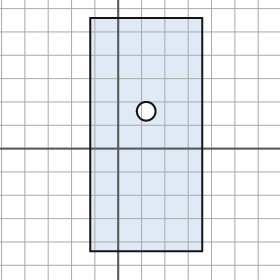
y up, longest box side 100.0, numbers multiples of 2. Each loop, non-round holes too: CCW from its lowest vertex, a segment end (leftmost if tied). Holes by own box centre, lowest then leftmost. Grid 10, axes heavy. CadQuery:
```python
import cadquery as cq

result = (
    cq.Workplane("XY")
    .moveTo(-12.0, -44.0)
    .lineTo(36.0, -44.0)
    .lineTo(36.0, 56.0)
    .lineTo(-12.0, 56.0)
    .close()
    .moveTo(12.0, 16.0)
    .circle(4.0)
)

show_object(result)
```